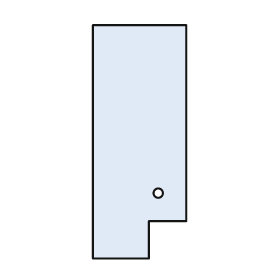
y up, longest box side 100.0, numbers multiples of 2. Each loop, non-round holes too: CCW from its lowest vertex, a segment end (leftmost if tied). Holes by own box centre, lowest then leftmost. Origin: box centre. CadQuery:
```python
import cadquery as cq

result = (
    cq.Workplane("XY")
    .moveTo(-20.0, -50.0)
    .lineTo(4.0, -50.0)
    .lineTo(4.0, -34.0)
    .lineTo(20.0, -34.0)
    .lineTo(20.0, 50.0)
    .lineTo(-20.0, 50.0)
    .close()
    .moveTo(8.0, -22.0)
    .circle(2.0)
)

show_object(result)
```